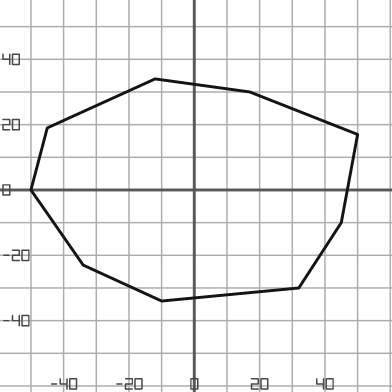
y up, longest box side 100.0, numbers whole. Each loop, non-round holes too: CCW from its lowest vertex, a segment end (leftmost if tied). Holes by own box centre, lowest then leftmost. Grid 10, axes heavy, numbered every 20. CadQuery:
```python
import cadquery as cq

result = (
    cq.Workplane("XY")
    .moveTo(-10.0, -34.0)
    .lineTo(32.0, -30.0)
    .lineTo(45.0, -10.0)
    .lineTo(50.0, 17.0)
    .lineTo(17.0, 30.0)
    .lineTo(-12.0, 34.0)
    .lineTo(-45.0, 19.0)
    .lineTo(-50.0, 0.0)
    .lineTo(-34.0, -23.0)
    .close()
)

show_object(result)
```